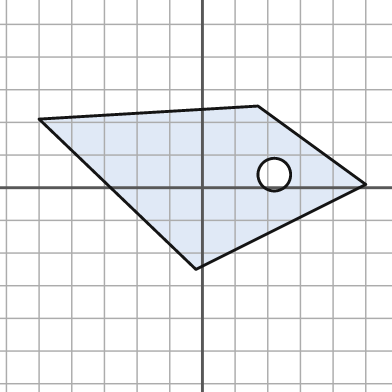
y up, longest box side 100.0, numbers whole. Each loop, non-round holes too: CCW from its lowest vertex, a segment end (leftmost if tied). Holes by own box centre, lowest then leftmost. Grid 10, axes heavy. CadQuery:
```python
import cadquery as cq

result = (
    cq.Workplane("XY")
    .moveTo(-2.0, -25.0)
    .lineTo(50.0, 1.0)
    .lineTo(17.0, 25.0)
    .lineTo(-50.0, 21.0)
    .close()
    .moveTo(22.0, 4.0)
    .circle(5.0)
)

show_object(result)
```